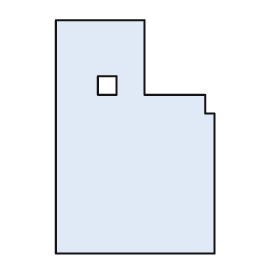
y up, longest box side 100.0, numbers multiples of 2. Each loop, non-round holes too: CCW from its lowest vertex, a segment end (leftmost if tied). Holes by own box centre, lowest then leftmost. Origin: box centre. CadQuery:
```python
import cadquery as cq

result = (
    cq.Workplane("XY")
    .moveTo(-34.0, -50.0)
    .lineTo(34.0, -50.0)
    .lineTo(34.0, 10.0)
    .lineTo(30.0, 10.0)
    .lineTo(30.0, 18.0)
    .lineTo(4.0, 18.0)
    .lineTo(4.0, 50.0)
    .lineTo(-34.0, 50.0)
    .close()
    .moveTo(-16.0, 18.0)
    .lineTo(-8.0, 18.0)
    .lineTo(-8.0, 26.0)
    .lineTo(-16.0, 26.0)
    .close()
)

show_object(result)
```